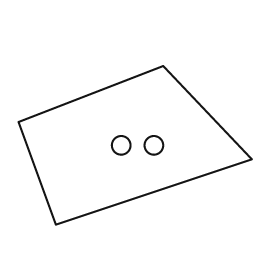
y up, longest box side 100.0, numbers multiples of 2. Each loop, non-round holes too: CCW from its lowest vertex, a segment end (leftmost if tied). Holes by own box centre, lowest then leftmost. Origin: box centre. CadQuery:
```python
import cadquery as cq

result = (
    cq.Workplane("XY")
    .moveTo(-34.0, -34.0)
    .lineTo(50.0, -6.0)
    .lineTo(12.0, 34.0)
    .lineTo(-50.0, 10.0)
    .close()
    .moveTo(-6.0, 0.0)
    .circle(4.0)
    .moveTo(8.0, 0.0)
    .circle(4.0)
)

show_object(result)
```